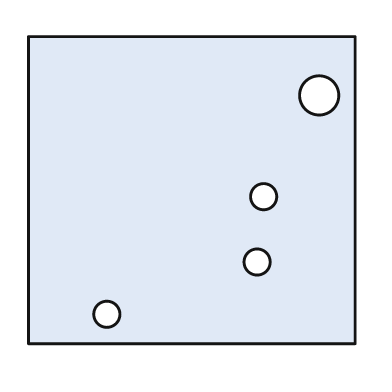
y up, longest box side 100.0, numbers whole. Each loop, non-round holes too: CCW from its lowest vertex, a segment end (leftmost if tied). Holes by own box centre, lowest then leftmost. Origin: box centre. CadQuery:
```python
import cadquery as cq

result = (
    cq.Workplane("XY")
    .moveTo(-50.0, -47.0)
    .lineTo(50.0, -47.0)
    .lineTo(50.0, 47.0)
    .lineTo(-50.0, 47.0)
    .close()
    .moveTo(-26.0, -38.0)
    .circle(4.0)
    .moveTo(20.0, -22.0)
    .circle(4.0)
    .moveTo(22.0, -2.0)
    .circle(4.0)
    .moveTo(39.0, 29.0)
    .circle(6.0)
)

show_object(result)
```